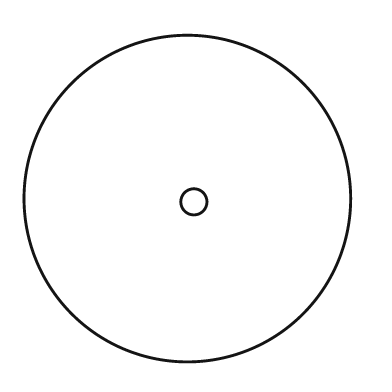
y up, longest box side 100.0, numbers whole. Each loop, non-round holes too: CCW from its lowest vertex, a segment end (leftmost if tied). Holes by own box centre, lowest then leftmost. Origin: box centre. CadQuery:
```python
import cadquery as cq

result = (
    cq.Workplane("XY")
    .moveTo(0.0, 0.0)
    .circle(50.0)
    .moveTo(2.0, -1.0)
    .circle(4.0)
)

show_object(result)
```